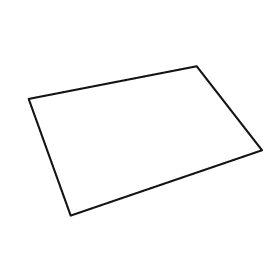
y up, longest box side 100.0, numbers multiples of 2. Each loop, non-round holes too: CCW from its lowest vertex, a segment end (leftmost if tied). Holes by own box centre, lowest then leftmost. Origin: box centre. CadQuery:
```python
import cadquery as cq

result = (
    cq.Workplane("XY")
    .moveTo(-32.0, -32.0)
    .lineTo(50.0, -4.0)
    .lineTo(22.0, 32.0)
    .lineTo(-50.0, 18.0)
    .close()
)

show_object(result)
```